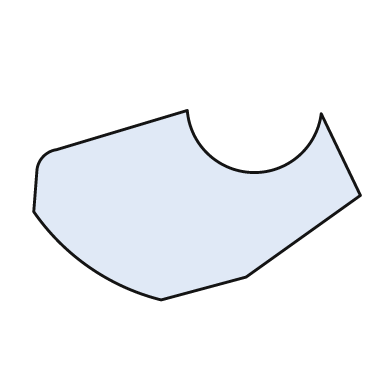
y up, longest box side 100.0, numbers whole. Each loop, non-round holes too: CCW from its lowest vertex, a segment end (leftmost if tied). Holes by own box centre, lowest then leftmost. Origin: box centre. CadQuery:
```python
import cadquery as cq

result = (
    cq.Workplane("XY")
    .moveTo(-11.0, -29.0)
    .lineTo(15.0, -22.0)
    .lineTo(50.0, 3.0)
    .lineTo(38.0, 28.0)
    .threePointArc((17.0, 10.0), (-3.0, 29.0))
    .lineTo(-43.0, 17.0)
    .threePointArc((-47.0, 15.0), (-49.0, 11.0))
    .lineTo(-50.0, -2.0)
    .threePointArc((-33.0, -19.0), (-11.0, -29.0))
    .close()
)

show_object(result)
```